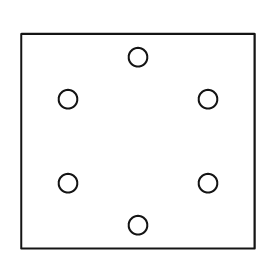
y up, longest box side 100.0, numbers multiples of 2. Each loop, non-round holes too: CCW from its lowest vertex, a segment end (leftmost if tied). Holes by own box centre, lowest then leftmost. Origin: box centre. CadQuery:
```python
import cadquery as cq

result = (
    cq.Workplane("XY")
    .moveTo(-50.0, -46.0)
    .lineTo(50.0, -46.0)
    .lineTo(50.0, 46.0)
    .lineTo(-50.0, 46.0)
    .close()
    .moveTo(0.0, -36.0)
    .circle(4.0)
    .moveTo(-30.0, -18.0)
    .circle(4.0)
    .moveTo(30.0, -18.0)
    .circle(4.0)
    .moveTo(-30.0, 18.0)
    .circle(4.0)
    .moveTo(30.0, 18.0)
    .circle(4.0)
    .moveTo(0.0, 36.0)
    .circle(4.0)
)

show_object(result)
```